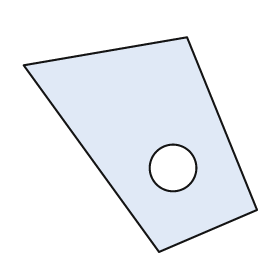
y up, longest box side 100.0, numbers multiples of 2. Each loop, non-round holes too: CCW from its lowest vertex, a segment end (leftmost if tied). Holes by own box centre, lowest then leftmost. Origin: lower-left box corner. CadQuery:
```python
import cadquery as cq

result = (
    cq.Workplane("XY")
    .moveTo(58.0, 0.0)
    .lineTo(100.0, 18.0)
    .lineTo(70.0, 92.0)
    .lineTo(0.0, 80.0)
    .close()
    .moveTo(64.0, 36.0)
    .circle(10.0)
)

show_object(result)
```